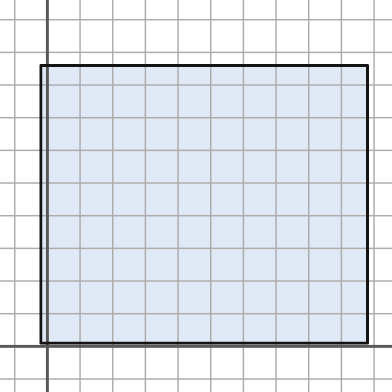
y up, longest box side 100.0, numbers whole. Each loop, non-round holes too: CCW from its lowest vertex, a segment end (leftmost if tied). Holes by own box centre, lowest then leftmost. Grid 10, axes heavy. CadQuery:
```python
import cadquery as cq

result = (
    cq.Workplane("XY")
    .moveTo(-2.0, 1.0)
    .lineTo(98.0, 1.0)
    .lineTo(98.0, 86.0)
    .lineTo(-2.0, 86.0)
    .close()
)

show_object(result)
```